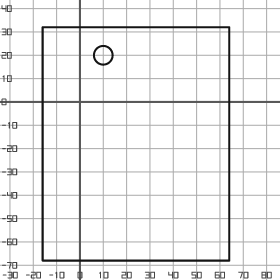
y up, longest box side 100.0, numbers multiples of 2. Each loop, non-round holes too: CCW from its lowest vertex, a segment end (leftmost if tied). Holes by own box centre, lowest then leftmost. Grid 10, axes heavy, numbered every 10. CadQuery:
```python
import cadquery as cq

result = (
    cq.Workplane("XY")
    .moveTo(-16.0, -68.0)
    .lineTo(64.0, -68.0)
    .lineTo(64.0, 32.0)
    .lineTo(-16.0, 32.0)
    .close()
    .moveTo(10.0, 20.0)
    .circle(4.0)
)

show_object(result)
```